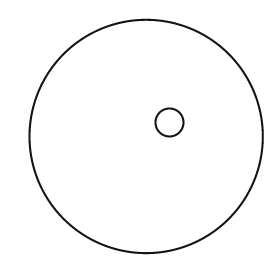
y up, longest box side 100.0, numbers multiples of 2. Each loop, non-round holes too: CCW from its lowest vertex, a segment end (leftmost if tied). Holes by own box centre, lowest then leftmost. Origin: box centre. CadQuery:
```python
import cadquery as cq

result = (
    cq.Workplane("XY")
    .moveTo(0.0, 0.0)
    .circle(50.0)
    .moveTo(10.0, 6.0)
    .circle(6.0)
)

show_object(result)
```